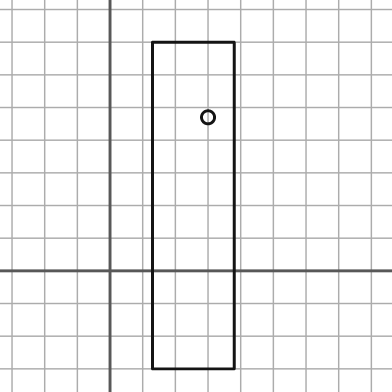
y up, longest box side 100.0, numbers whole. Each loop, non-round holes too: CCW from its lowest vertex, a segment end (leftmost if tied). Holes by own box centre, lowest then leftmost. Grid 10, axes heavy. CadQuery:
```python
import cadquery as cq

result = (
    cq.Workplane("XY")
    .moveTo(13.0, -30.0)
    .lineTo(38.0, -30.0)
    .lineTo(38.0, 70.0)
    .lineTo(13.0, 70.0)
    .close()
    .moveTo(30.0, 47.0)
    .circle(2.0)
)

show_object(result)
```